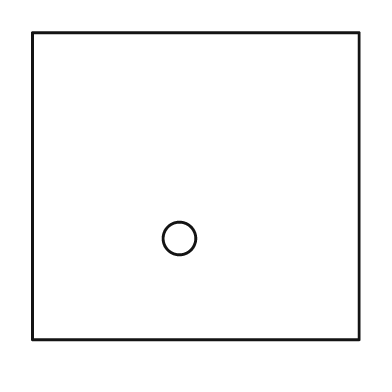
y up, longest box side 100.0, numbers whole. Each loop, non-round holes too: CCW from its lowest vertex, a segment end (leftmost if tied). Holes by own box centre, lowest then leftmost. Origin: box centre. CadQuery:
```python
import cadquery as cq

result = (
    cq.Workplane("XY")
    .moveTo(-50.0, -47.0)
    .lineTo(50.0, -47.0)
    .lineTo(50.0, 47.0)
    .lineTo(-50.0, 47.0)
    .close()
    .moveTo(-5.0, -16.0)
    .circle(5.0)
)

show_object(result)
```